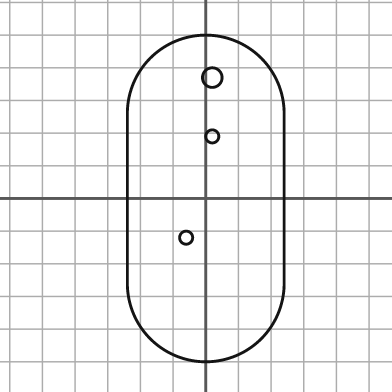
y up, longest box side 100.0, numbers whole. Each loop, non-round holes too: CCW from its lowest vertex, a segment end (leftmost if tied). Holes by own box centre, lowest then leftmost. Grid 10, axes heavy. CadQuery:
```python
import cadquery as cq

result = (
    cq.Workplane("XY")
    .moveTo(-24.0, -26.0)
    .threePointArc((0.0, -50.0), (24.0, -26.0))
    .lineTo(24.0, 26.0)
    .threePointArc((0.0, 50.0), (-24.0, 26.0))
    .close()
    .moveTo(-6.0, -12.0)
    .circle(2.0)
    .moveTo(2.0, 19.0)
    .circle(2.0)
    .moveTo(2.0, 37.0)
    .circle(3.0)
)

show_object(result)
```